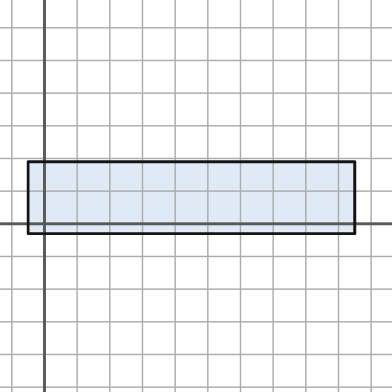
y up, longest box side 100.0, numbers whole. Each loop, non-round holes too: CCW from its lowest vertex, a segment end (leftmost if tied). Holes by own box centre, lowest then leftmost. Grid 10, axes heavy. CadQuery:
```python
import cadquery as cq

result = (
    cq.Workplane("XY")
    .moveTo(-5.0, -3.0)
    .lineTo(95.0, -3.0)
    .lineTo(95.0, 19.0)
    .lineTo(-5.0, 19.0)
    .close()
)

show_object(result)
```